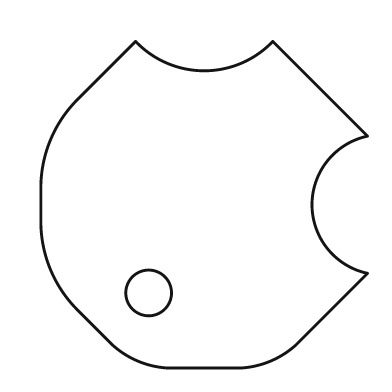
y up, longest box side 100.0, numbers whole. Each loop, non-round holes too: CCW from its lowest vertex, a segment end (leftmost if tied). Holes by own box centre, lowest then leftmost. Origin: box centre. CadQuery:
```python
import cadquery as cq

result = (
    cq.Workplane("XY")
    .moveTo(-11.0, -50.0)
    .lineTo(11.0, -50.0)
    .threePointArc((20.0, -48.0), (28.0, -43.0))
    .lineTo(50.0, -21.0)
    .threePointArc((33.0, 0.0), (50.0, 21.0))
    .lineTo(21.0, 50.0)
    .threePointArc((0.0, 41.0), (-21.0, 50.0))
    .lineTo(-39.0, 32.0)
    .threePointArc((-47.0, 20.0), (-50.0, 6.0))
    .lineTo(-50.0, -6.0)
    .threePointArc((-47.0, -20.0), (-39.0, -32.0))
    .lineTo(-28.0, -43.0)
    .threePointArc((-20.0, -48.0), (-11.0, -50.0))
    .close()
    .moveTo(-17.0, -27.0)
    .circle(7.0)
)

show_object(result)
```